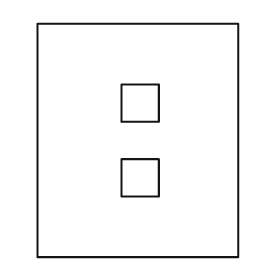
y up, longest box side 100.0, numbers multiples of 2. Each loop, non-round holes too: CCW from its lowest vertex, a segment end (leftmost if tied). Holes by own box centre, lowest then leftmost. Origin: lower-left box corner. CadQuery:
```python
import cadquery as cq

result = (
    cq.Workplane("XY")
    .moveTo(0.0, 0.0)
    .lineTo(86.0, 0.0)
    .lineTo(86.0, 100.0)
    .lineTo(0.0, 100.0)
    .close()
    .moveTo(36.0, 26.0)
    .lineTo(52.0, 26.0)
    .lineTo(52.0, 42.0)
    .lineTo(36.0, 42.0)
    .close()
    .moveTo(36.0, 58.0)
    .lineTo(52.0, 58.0)
    .lineTo(52.0, 74.0)
    .lineTo(36.0, 74.0)
    .close()
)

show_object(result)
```